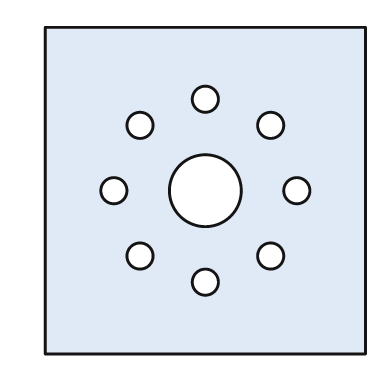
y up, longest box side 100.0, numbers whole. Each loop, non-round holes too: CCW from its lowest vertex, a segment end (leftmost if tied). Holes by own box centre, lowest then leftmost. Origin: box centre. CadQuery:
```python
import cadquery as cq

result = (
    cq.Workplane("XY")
    .moveTo(-49.0, -50.0)
    .lineTo(49.0, -50.0)
    .lineTo(49.0, 50.0)
    .lineTo(-49.0, 50.0)
    .close()
    .moveTo(0.0, -28.0)
    .circle(4.0)
    .moveTo(-20.0, -20.0)
    .circle(4.0)
    .moveTo(20.0, -20.0)
    .circle(4.0)
    .moveTo(-28.0, 0.0)
    .circle(4.0)
    .moveTo(0.0, 0.0)
    .circle(11.0)
    .moveTo(28.0, 0.0)
    .circle(4.0)
    .moveTo(-20.0, 20.0)
    .circle(4.0)
    .moveTo(20.0, 20.0)
    .circle(4.0)
    .moveTo(0.0, 28.0)
    .circle(4.0)
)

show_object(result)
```